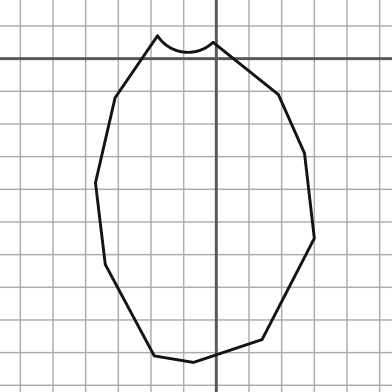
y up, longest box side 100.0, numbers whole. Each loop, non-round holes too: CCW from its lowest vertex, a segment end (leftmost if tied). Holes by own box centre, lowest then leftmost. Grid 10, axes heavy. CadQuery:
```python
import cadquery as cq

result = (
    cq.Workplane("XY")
    .moveTo(-7.0, -93.0)
    .lineTo(14.0, -86.0)
    .lineTo(30.0, -55.0)
    .lineTo(27.0, -29.0)
    .lineTo(19.0, -11.0)
    .lineTo(-1.0, 5.0)
    .threePointArc((-10.0, 2.0), (-18.0, 7.0))
    .lineTo(-31.0, -12.0)
    .lineTo(-37.0, -38.0)
    .lineTo(-34.0, -63.0)
    .lineTo(-19.0, -91.0)
    .close()
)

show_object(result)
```